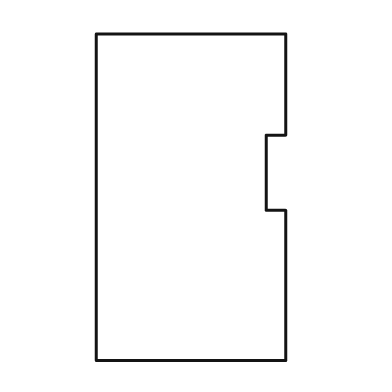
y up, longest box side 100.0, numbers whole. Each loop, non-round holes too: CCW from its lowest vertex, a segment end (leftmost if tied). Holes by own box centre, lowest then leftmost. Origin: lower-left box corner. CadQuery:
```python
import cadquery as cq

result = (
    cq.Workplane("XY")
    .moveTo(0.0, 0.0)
    .lineTo(58.0, 0.0)
    .lineTo(58.0, 46.0)
    .lineTo(52.0, 46.0)
    .lineTo(52.0, 69.0)
    .lineTo(58.0, 69.0)
    .lineTo(58.0, 100.0)
    .lineTo(0.0, 100.0)
    .close()
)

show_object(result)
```